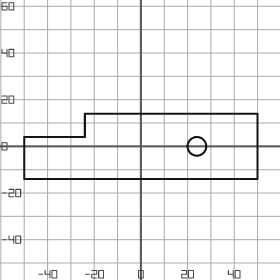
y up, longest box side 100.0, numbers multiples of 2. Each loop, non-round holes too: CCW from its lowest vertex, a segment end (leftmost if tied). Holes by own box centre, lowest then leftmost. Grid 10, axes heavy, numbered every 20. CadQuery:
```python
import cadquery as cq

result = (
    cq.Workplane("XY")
    .moveTo(-50.0, -14.0)
    .lineTo(50.0, -14.0)
    .lineTo(50.0, 14.0)
    .lineTo(-24.0, 14.0)
    .lineTo(-24.0, 4.0)
    .lineTo(-50.0, 4.0)
    .close()
    .moveTo(24.0, 0.0)
    .circle(4.0)
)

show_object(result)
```